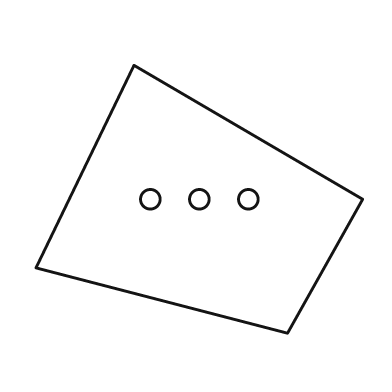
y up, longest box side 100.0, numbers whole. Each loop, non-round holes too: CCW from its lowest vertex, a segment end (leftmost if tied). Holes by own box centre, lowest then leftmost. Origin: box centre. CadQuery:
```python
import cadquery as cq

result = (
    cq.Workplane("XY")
    .moveTo(27.0, -41.0)
    .lineTo(50.0, 0.0)
    .lineTo(-20.0, 41.0)
    .lineTo(-50.0, -21.0)
    .close()
    .moveTo(-15.0, 0.0)
    .circle(3.0)
    .moveTo(0.0, 0.0)
    .circle(3.0)
    .moveTo(15.0, 0.0)
    .circle(3.0)
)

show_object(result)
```